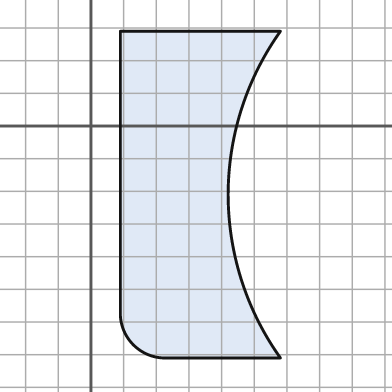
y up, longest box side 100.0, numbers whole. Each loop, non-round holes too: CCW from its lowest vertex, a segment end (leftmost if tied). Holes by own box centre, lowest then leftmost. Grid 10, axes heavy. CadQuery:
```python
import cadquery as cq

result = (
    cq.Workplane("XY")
    .moveTo(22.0, -71.0)
    .lineTo(58.0, -71.0)
    .threePointArc((42.0, -21.0), (58.0, 29.0))
    .lineTo(9.0, 29.0)
    .lineTo(9.0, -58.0)
    .threePointArc((13.0, -67.0), (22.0, -71.0))
    .close()
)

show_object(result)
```